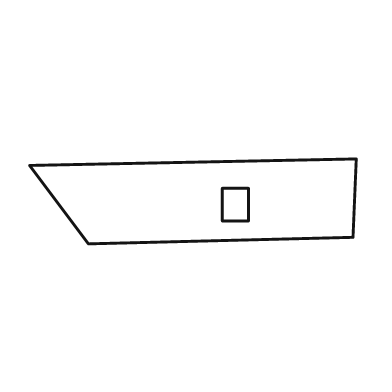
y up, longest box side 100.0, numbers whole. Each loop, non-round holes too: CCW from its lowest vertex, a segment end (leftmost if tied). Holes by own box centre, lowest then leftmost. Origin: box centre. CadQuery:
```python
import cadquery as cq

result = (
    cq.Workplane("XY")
    .moveTo(-32.0, -13.0)
    .lineTo(49.0, -11.0)
    .lineTo(50.0, 13.0)
    .lineTo(-50.0, 11.0)
    .close()
    .moveTo(9.0, -6.0)
    .lineTo(17.0, -6.0)
    .lineTo(17.0, 4.0)
    .lineTo(9.0, 4.0)
    .close()
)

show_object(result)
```